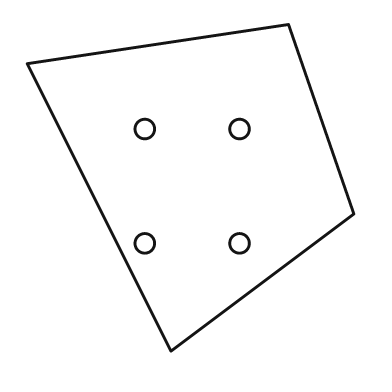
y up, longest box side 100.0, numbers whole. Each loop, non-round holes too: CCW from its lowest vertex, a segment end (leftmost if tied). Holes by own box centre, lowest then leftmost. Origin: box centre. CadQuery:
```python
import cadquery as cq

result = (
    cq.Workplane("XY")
    .moveTo(-6.0, -50.0)
    .lineTo(50.0, -8.0)
    .lineTo(30.0, 50.0)
    .lineTo(-50.0, 38.0)
    .close()
    .moveTo(-14.0, -17.0)
    .circle(3.0)
    .moveTo(15.0, -17.0)
    .circle(3.0)
    .moveTo(-14.0, 18.0)
    .circle(3.0)
    .moveTo(15.0, 18.0)
    .circle(3.0)
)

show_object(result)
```